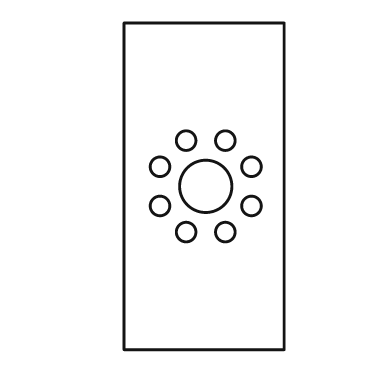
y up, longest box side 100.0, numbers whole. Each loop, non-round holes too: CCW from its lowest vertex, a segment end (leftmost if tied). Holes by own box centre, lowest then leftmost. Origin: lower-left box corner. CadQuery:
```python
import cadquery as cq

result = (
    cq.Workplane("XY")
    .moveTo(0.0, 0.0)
    .lineTo(49.0, 0.0)
    .lineTo(49.0, 100.0)
    .lineTo(0.0, 100.0)
    .close()
    .moveTo(19.0, 36.0)
    .circle(3.0)
    .moveTo(31.0, 36.0)
    .circle(3.0)
    .moveTo(11.0, 44.0)
    .circle(3.0)
    .moveTo(39.0, 44.0)
    .circle(3.0)
    .moveTo(25.0, 50.0)
    .circle(8.0)
    .moveTo(11.0, 56.0)
    .circle(3.0)
    .moveTo(39.0, 56.0)
    .circle(3.0)
    .moveTo(19.0, 64.0)
    .circle(3.0)
    .moveTo(31.0, 64.0)
    .circle(3.0)
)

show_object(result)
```